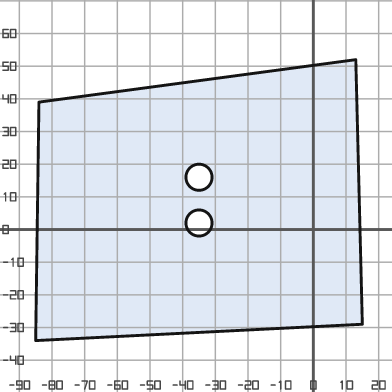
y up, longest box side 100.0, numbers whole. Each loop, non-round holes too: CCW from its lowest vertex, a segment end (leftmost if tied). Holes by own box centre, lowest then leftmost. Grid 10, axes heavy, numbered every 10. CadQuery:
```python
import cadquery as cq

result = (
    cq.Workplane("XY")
    .moveTo(-85.0, -34.0)
    .lineTo(15.0, -29.0)
    .lineTo(13.0, 52.0)
    .lineTo(-84.0, 39.0)
    .close()
    .moveTo(-35.0, 2.0)
    .circle(4.0)
    .moveTo(-35.0, 16.0)
    .circle(4.0)
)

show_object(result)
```